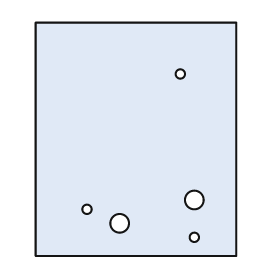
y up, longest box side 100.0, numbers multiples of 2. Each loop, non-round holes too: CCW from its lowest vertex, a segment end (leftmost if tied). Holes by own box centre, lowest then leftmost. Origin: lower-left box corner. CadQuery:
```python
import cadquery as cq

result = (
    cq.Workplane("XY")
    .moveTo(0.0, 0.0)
    .lineTo(86.0, 0.0)
    .lineTo(86.0, 100.0)
    .lineTo(0.0, 100.0)
    .close()
    .moveTo(68.0, 8.0)
    .circle(2.0)
    .moveTo(36.0, 14.0)
    .circle(4.0)
    .moveTo(22.0, 20.0)
    .circle(2.0)
    .moveTo(68.0, 24.0)
    .circle(4.0)
    .moveTo(62.0, 78.0)
    .circle(2.0)
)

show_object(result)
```